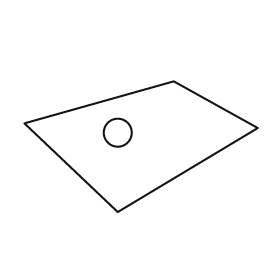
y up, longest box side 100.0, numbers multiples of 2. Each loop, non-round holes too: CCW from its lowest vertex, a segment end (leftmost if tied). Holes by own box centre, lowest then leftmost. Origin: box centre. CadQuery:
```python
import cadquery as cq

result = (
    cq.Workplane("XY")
    .moveTo(-10.0, -28.0)
    .lineTo(50.0, 8.0)
    .lineTo(14.0, 28.0)
    .lineTo(-50.0, 10.0)
    .close()
    .moveTo(-10.0, 6.0)
    .circle(6.0)
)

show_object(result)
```